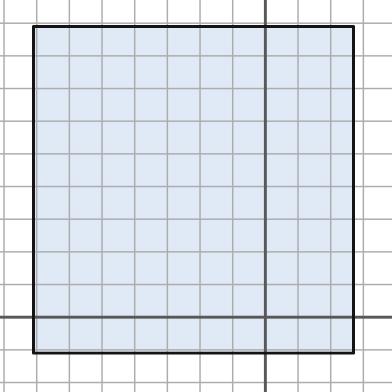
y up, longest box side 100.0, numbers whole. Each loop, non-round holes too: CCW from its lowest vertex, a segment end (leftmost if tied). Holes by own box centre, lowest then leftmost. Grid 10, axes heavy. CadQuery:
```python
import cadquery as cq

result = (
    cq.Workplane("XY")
    .moveTo(-71.0, -11.0)
    .lineTo(27.0, -11.0)
    .lineTo(27.0, 89.0)
    .lineTo(-71.0, 89.0)
    .close()
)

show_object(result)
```